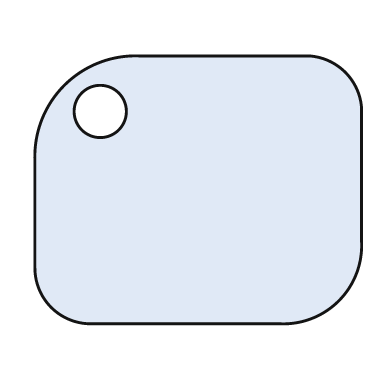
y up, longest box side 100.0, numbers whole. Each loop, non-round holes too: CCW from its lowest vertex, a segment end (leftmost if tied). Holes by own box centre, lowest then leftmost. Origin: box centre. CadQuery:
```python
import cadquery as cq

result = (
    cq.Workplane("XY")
    .moveTo(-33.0, -41.0)
    .lineTo(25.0, -41.0)
    .threePointArc((43.0, -34.0), (50.0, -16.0))
    .lineTo(50.0, 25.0)
    .threePointArc((45.0, 36.0), (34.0, 41.0))
    .lineTo(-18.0, 41.0)
    .threePointArc((-41.0, 32.0), (-50.0, 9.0))
    .lineTo(-50.0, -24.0)
    .threePointArc((-45.0, -36.0), (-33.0, -41.0))
    .close()
    .moveTo(-30.0, 24.0)
    .circle(8.0)
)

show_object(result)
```